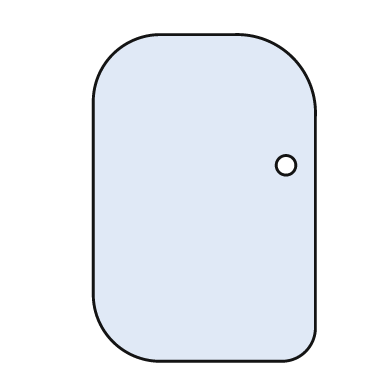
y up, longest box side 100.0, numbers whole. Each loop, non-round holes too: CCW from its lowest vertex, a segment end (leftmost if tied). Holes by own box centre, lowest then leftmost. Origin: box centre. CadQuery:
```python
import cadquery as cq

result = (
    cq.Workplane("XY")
    .moveTo(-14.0, -50.0)
    .lineTo(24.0, -50.0)
    .threePointArc((31.0, -47.0), (34.0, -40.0))
    .lineTo(34.0, 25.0)
    .threePointArc((27.0, 43.0), (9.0, 50.0))
    .lineTo(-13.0, 50.0)
    .threePointArc((-28.0, 44.0), (-34.0, 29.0))
    .lineTo(-34.0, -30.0)
    .threePointArc((-28.0, -44.0), (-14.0, -50.0))
    .close()
    .moveTo(25.0, 10.0)
    .circle(3.0)
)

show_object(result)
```